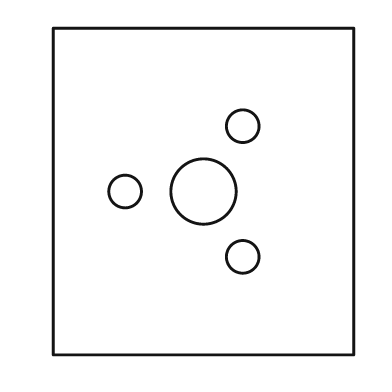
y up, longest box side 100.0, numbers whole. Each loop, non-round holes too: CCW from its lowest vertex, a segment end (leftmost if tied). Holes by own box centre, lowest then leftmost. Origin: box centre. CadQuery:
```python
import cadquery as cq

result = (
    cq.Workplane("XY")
    .moveTo(-46.0, -50.0)
    .lineTo(46.0, -50.0)
    .lineTo(46.0, 50.0)
    .lineTo(-46.0, 50.0)
    .close()
    .moveTo(12.0, -20.0)
    .circle(5.0)
    .moveTo(-24.0, 0.0)
    .circle(5.0)
    .moveTo(0.0, 0.0)
    .circle(10.0)
    .moveTo(12.0, 20.0)
    .circle(5.0)
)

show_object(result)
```